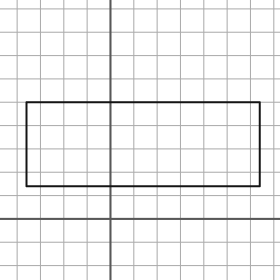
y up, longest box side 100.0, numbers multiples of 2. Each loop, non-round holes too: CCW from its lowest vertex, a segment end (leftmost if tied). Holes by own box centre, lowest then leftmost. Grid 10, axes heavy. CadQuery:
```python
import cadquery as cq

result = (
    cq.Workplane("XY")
    .moveTo(-36.0, 14.0)
    .lineTo(64.0, 14.0)
    .lineTo(64.0, 50.0)
    .lineTo(-36.0, 50.0)
    .close()
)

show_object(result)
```